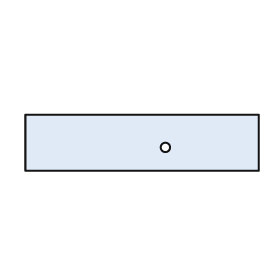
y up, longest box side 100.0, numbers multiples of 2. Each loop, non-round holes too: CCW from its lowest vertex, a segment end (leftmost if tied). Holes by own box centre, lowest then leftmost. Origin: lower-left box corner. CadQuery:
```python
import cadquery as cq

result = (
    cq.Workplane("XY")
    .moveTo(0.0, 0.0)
    .lineTo(100.0, 0.0)
    .lineTo(100.0, 24.0)
    .lineTo(0.0, 24.0)
    .close()
    .moveTo(60.0, 10.0)
    .circle(2.0)
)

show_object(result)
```